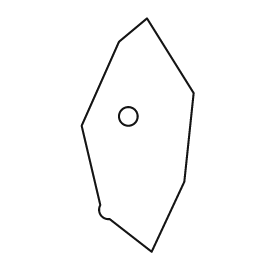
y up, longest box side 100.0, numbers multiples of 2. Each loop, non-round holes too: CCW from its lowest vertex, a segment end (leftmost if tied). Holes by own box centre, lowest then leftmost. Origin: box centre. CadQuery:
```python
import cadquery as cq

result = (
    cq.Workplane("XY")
    .moveTo(6.0, -50.0)
    .lineTo(20.0, -20.0)
    .lineTo(24.0, 18.0)
    .lineTo(4.0, 50.0)
    .lineTo(-8.0, 40.0)
    .lineTo(-24.0, 4.0)
    .lineTo(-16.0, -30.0)
    .threePointArc((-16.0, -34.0), (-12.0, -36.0))
    .close()
    .moveTo(-4.0, 8.0)
    .circle(4.0)
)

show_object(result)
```